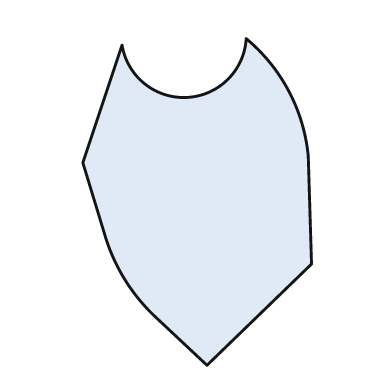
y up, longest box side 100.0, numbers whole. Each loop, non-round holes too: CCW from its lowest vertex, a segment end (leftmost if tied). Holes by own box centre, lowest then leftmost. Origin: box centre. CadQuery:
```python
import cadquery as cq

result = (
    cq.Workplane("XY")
    .moveTo(3.0, -50.0)
    .lineTo(35.0, -19.0)
    .lineTo(34.0, 14.0)
    .threePointArc((28.0, 34.0), (15.0, 50.0))
    .threePointArc((-3.0, 32.0), (-23.0, 48.0))
    .lineTo(-35.0, 12.0)
    .lineTo(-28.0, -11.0)
    .threePointArc((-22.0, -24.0), (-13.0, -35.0))
    .close()
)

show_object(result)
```